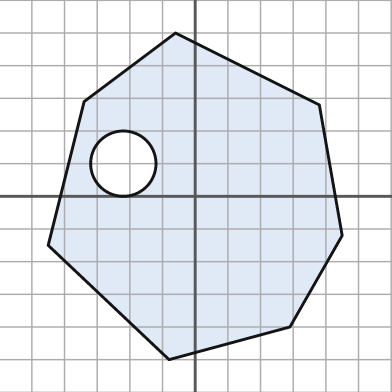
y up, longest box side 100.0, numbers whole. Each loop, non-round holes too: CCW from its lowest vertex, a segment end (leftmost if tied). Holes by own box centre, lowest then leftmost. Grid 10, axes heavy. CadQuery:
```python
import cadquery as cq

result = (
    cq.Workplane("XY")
    .moveTo(-8.0, -50.0)
    .lineTo(29.0, -40.0)
    .lineTo(45.0, -12.0)
    .lineTo(38.0, 28.0)
    .lineTo(-6.0, 50.0)
    .lineTo(-34.0, 29.0)
    .lineTo(-45.0, -15.0)
    .close()
    .moveTo(-22.0, 10.0)
    .circle(10.0)
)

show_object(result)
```